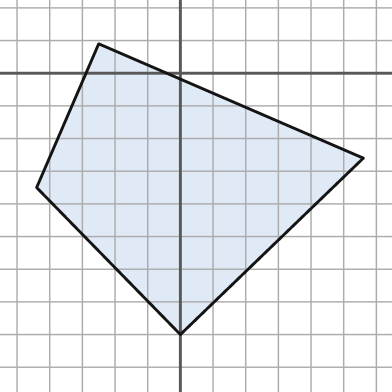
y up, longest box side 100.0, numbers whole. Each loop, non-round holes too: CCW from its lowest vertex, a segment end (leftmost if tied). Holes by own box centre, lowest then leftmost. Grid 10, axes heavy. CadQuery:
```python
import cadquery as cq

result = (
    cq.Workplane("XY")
    .moveTo(0.0, -80.0)
    .lineTo(56.0, -26.0)
    .lineTo(-25.0, 9.0)
    .lineTo(-44.0, -35.0)
    .close()
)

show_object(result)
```